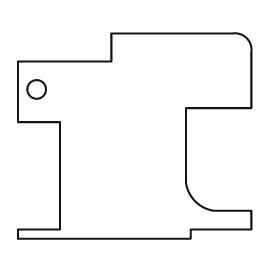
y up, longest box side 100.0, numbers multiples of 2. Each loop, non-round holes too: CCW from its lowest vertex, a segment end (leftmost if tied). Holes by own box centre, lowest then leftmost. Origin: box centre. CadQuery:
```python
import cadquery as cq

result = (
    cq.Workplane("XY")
    .moveTo(-50.0, -44.0)
    .lineTo(24.0, -44.0)
    .lineTo(24.0, -40.0)
    .lineTo(50.0, -40.0)
    .lineTo(50.0, -32.0)
    .lineTo(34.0, -32.0)
    .threePointArc((26.0, -28.0), (22.0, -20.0))
    .lineTo(22.0, 12.0)
    .lineTo(50.0, 12.0)
    .lineTo(50.0, 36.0)
    .threePointArc((48.0, 42.0), (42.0, 44.0))
    .lineTo(-10.0, 44.0)
    .lineTo(-10.0, 32.0)
    .lineTo(-50.0, 32.0)
    .lineTo(-50.0, 6.0)
    .lineTo(-32.0, 6.0)
    .lineTo(-32.0, -40.0)
    .lineTo(-50.0, -40.0)
    .close()
    .moveTo(-42.0, 20.0)
    .circle(4.0)
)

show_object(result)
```